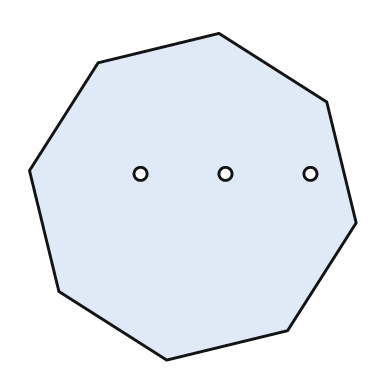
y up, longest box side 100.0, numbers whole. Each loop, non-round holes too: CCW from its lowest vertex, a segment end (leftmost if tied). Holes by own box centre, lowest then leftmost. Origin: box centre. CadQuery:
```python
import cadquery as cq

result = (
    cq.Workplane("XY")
    .moveTo(-8.0, -50.0)
    .lineTo(29.0, -41.0)
    .lineTo(50.0, -8.0)
    .lineTo(41.0, 29.0)
    .lineTo(8.0, 50.0)
    .lineTo(-29.0, 41.0)
    .lineTo(-50.0, 8.0)
    .lineTo(-41.0, -29.0)
    .close()
    .moveTo(-16.0, 7.0)
    .circle(2.0)
    .moveTo(10.0, 7.0)
    .circle(2.0)
    .moveTo(36.0, 7.0)
    .circle(2.0)
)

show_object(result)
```